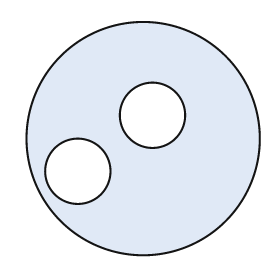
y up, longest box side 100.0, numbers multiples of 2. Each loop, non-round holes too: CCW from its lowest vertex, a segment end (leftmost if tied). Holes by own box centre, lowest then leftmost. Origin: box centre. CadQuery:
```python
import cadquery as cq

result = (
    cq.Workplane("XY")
    .moveTo(0.0, 0.0)
    .circle(50.0)
    .moveTo(-28.0, -14.0)
    .circle(14.0)
    .moveTo(4.0, 10.0)
    .circle(14.0)
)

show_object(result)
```